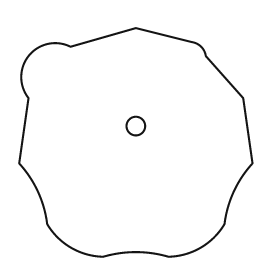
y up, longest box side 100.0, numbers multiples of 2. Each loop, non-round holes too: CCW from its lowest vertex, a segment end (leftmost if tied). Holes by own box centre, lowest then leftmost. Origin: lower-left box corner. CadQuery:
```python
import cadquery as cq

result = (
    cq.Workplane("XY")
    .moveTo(36.0, 0.0)
    .threePointArc((50.0, 2.0), (64.0, 0.0))
    .threePointArc((78.0, 4.0), (88.0, 14.0))
    .threePointArc((92.0, 28.0), (100.0, 40.0))
    .lineTo(96.0, 68.0)
    .lineTo(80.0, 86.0)
    .threePointArc((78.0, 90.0), (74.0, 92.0))
    .lineTo(50.0, 98.0)
    .lineTo(22.0, 90.0)
    .threePointArc((4.0, 86.0), (4.0, 68.0))
    .lineTo(0.0, 40.0)
    .threePointArc((8.0, 28.0), (12.0, 14.0))
    .threePointArc((22.0, 4.0), (36.0, 0.0))
    .close()
    .moveTo(50.0, 56.0)
    .circle(4.0)
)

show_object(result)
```